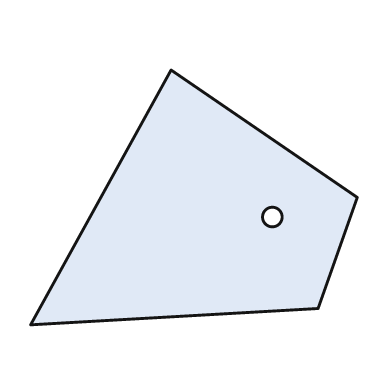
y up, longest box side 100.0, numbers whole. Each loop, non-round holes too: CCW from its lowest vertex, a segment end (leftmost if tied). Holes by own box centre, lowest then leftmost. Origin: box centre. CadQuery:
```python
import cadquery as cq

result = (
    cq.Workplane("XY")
    .moveTo(-50.0, -39.0)
    .lineTo(38.0, -34.0)
    .lineTo(50.0, 0.0)
    .lineTo(-7.0, 39.0)
    .close()
    .moveTo(24.0, -6.0)
    .circle(3.0)
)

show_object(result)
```